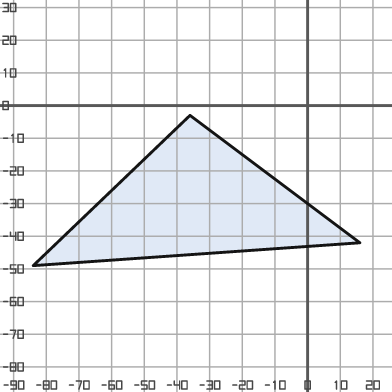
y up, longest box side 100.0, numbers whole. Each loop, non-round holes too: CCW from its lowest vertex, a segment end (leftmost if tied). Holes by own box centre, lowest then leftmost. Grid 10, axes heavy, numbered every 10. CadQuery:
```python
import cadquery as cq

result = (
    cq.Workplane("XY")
    .moveTo(-84.0, -49.0)
    .lineTo(16.0, -42.0)
    .lineTo(-36.0, -3.0)
    .close()
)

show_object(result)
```